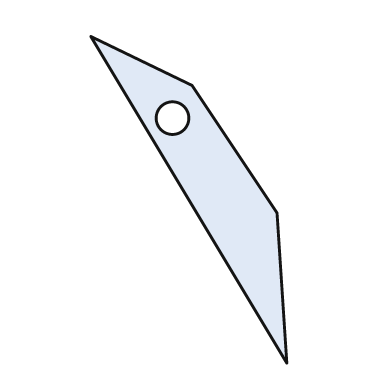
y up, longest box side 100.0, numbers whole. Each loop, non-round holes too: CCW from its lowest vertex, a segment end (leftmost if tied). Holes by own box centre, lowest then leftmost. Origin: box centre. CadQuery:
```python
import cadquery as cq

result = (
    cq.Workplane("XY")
    .moveTo(30.0, -50.0)
    .lineTo(27.0, -4.0)
    .lineTo(1.0, 35.0)
    .lineTo(-30.0, 50.0)
    .close()
    .moveTo(-5.0, 25.0)
    .circle(5.0)
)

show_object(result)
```